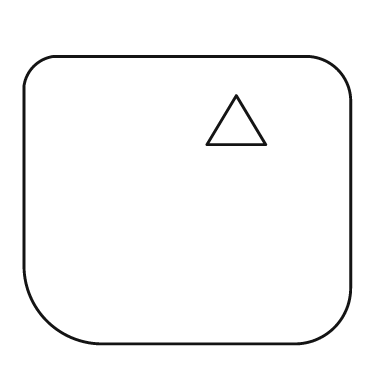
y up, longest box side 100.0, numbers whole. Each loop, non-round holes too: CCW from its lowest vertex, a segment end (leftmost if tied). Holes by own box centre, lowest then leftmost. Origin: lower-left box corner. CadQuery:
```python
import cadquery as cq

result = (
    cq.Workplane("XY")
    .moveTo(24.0, 0.0)
    .lineTo(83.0, 0.0)
    .threePointArc((95.0, 5.0), (100.0, 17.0))
    .lineTo(100.0, 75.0)
    .threePointArc((96.0, 84.0), (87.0, 88.0))
    .lineTo(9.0, 88.0)
    .threePointArc((3.0, 85.0), (0.0, 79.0))
    .lineTo(0.0, 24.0)
    .threePointArc((7.0, 7.0), (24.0, 0.0))
    .close()
    .moveTo(56.0, 61.0)
    .lineTo(74.0, 61.0)
    .lineTo(65.0, 76.0)
    .close()
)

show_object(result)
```